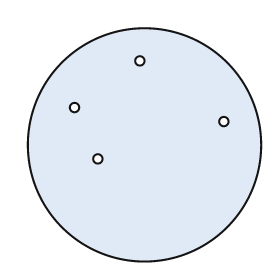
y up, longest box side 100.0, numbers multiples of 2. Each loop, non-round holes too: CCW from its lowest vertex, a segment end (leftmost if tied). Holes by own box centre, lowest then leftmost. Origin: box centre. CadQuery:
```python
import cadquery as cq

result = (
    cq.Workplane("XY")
    .moveTo(0.0, 0.0)
    .circle(50.0)
    .moveTo(-20.0, -6.0)
    .circle(2.0)
    .moveTo(34.0, 10.0)
    .circle(2.0)
    .moveTo(-30.0, 16.0)
    .circle(2.0)
    .moveTo(-2.0, 36.0)
    .circle(2.0)
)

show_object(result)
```